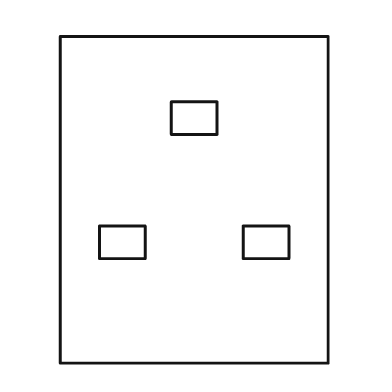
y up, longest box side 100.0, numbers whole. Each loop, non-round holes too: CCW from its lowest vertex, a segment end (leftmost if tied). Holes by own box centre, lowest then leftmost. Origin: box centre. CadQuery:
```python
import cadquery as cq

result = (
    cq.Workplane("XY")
    .moveTo(-41.0, -50.0)
    .lineTo(41.0, -50.0)
    .lineTo(41.0, 50.0)
    .lineTo(-41.0, 50.0)
    .close()
    .moveTo(-29.0, -18.0)
    .lineTo(-15.0, -18.0)
    .lineTo(-15.0, -8.0)
    .lineTo(-29.0, -8.0)
    .close()
    .moveTo(15.0, -18.0)
    .lineTo(29.0, -18.0)
    .lineTo(29.0, -8.0)
    .lineTo(15.0, -8.0)
    .close()
    .moveTo(-7.0, 20.0)
    .lineTo(7.0, 20.0)
    .lineTo(7.0, 30.0)
    .lineTo(-7.0, 30.0)
    .close()
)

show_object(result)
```